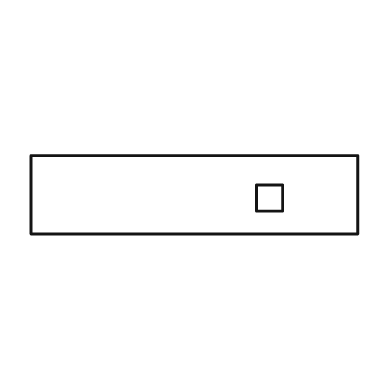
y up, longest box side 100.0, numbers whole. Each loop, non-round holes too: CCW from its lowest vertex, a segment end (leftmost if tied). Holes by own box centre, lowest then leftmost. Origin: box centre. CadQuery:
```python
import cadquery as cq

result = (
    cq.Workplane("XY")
    .moveTo(-50.0, -12.0)
    .lineTo(50.0, -12.0)
    .lineTo(50.0, 12.0)
    .lineTo(-50.0, 12.0)
    .close()
    .moveTo(19.0, -5.0)
    .lineTo(27.0, -5.0)
    .lineTo(27.0, 3.0)
    .lineTo(19.0, 3.0)
    .close()
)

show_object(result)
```